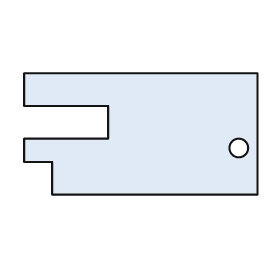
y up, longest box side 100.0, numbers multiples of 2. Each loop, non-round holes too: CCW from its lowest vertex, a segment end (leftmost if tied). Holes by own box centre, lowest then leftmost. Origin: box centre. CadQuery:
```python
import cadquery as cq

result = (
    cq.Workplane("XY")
    .moveTo(-38.0, -26.0)
    .lineTo(50.0, -26.0)
    .lineTo(50.0, 26.0)
    .lineTo(-50.0, 26.0)
    .lineTo(-50.0, 12.0)
    .lineTo(-14.0, 12.0)
    .lineTo(-14.0, -2.0)
    .lineTo(-50.0, -2.0)
    .lineTo(-50.0, -12.0)
    .lineTo(-38.0, -12.0)
    .close()
    .moveTo(42.0, -6.0)
    .circle(4.0)
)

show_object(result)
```